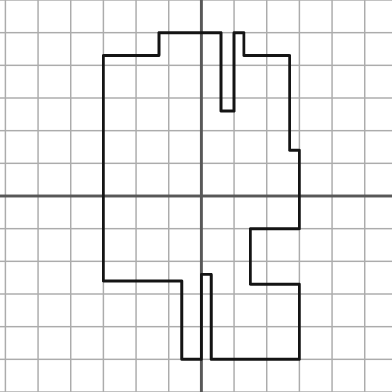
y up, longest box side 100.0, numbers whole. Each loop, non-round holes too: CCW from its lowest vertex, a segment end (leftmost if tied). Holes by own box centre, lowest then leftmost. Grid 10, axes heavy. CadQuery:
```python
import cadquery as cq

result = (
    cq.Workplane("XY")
    .moveTo(-6.0, -50.0)
    .lineTo(0.0, -50.0)
    .lineTo(0.0, -24.0)
    .lineTo(3.0, -24.0)
    .lineTo(3.0, -50.0)
    .lineTo(30.0, -50.0)
    .lineTo(30.0, -27.0)
    .lineTo(15.0, -27.0)
    .lineTo(15.0, -10.0)
    .lineTo(30.0, -10.0)
    .lineTo(30.0, 14.0)
    .lineTo(27.0, 14.0)
    .lineTo(27.0, 43.0)
    .lineTo(13.0, 43.0)
    .lineTo(13.0, 50.0)
    .lineTo(10.0, 50.0)
    .lineTo(10.0, 26.0)
    .lineTo(6.0, 26.0)
    .lineTo(6.0, 50.0)
    .lineTo(-13.0, 50.0)
    .lineTo(-13.0, 43.0)
    .lineTo(-30.0, 43.0)
    .lineTo(-30.0, -26.0)
    .lineTo(-6.0, -26.0)
    .close()
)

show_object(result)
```